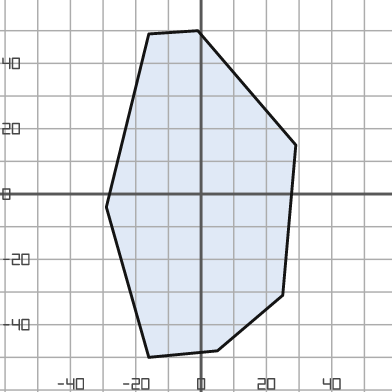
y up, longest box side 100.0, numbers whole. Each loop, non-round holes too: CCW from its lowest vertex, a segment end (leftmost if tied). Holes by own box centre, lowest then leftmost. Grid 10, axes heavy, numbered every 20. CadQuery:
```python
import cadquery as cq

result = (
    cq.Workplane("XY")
    .moveTo(-16.0, -50.0)
    .lineTo(5.0, -48.0)
    .lineTo(25.0, -31.0)
    .lineTo(29.0, 15.0)
    .lineTo(-1.0, 50.0)
    .lineTo(-16.0, 49.0)
    .lineTo(-29.0, -4.0)
    .close()
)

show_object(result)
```